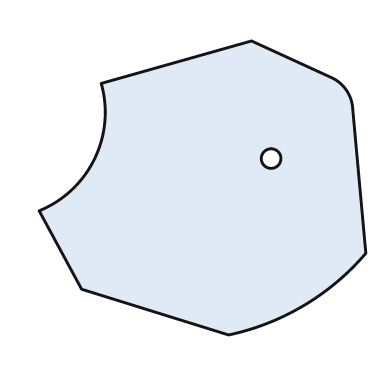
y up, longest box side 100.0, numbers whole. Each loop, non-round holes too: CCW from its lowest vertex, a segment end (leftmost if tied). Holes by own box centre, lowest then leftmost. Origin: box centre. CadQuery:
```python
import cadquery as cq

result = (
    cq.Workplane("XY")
    .moveTo(8.0, -45.0)
    .threePointArc((31.0, -36.0), (50.0, -20.0))
    .lineTo(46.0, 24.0)
    .threePointArc((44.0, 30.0), (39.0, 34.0))
    .lineTo(15.0, 45.0)
    .lineTo(-31.0, 32.0)
    .threePointArc((-33.0, 9.0), (-50.0, -7.0))
    .lineTo(-37.0, -31.0)
    .close()
    .moveTo(21.0, 9.0)
    .circle(3.0)
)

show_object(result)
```